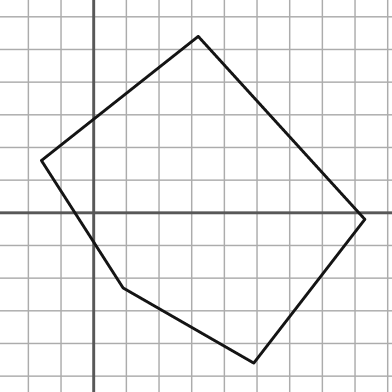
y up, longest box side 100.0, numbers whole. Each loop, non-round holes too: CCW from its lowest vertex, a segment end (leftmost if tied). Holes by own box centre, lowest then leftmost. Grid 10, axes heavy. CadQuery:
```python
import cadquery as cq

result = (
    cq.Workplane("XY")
    .moveTo(49.0, -46.0)
    .lineTo(83.0, -2.0)
    .lineTo(32.0, 54.0)
    .lineTo(-16.0, 16.0)
    .lineTo(9.0, -23.0)
    .close()
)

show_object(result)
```